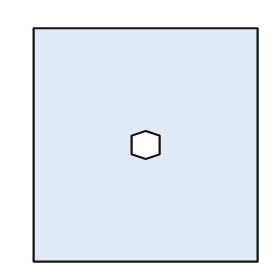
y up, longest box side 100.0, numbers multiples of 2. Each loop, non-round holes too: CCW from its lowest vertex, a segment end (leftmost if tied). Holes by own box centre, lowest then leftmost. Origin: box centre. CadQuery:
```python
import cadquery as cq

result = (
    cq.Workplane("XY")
    .moveTo(-48.0, -50.0)
    .lineTo(48.0, -50.0)
    .lineTo(48.0, 50.0)
    .lineTo(-48.0, 50.0)
    .close()
    .moveTo(0.0, -6.0)
    .lineTo(6.0, -4.0)
    .lineTo(6.0, 4.0)
    .lineTo(0.0, 6.0)
    .lineTo(-6.0, 4.0)
    .lineTo(-6.0, -4.0)
    .close()
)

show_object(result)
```